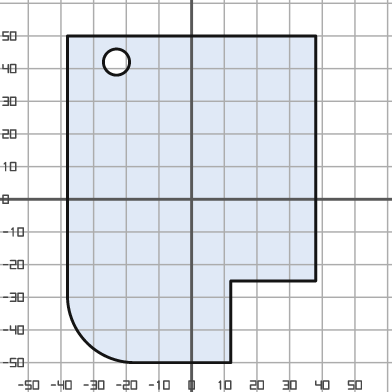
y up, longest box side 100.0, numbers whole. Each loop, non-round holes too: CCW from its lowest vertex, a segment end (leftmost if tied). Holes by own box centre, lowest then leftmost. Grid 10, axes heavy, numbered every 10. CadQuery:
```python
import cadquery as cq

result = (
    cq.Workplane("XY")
    .moveTo(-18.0, -50.0)
    .lineTo(12.0, -50.0)
    .lineTo(12.0, -25.0)
    .lineTo(38.0, -25.0)
    .lineTo(38.0, 50.0)
    .lineTo(-38.0, 50.0)
    .lineTo(-38.0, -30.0)
    .threePointArc((-32.0, -44.0), (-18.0, -50.0))
    .close()
    .moveTo(-23.0, 42.0)
    .circle(4.0)
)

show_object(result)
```